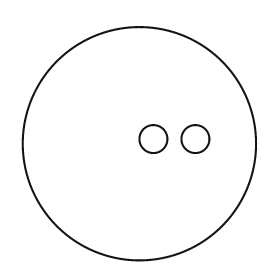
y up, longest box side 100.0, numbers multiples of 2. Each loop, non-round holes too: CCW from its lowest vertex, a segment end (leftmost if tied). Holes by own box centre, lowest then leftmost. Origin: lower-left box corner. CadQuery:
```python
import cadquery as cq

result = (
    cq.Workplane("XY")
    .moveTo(50.0, 50.0)
    .circle(50.0)
    .moveTo(56.0, 52.0)
    .circle(6.0)
    .moveTo(74.0, 52.0)
    .circle(6.0)
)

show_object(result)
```